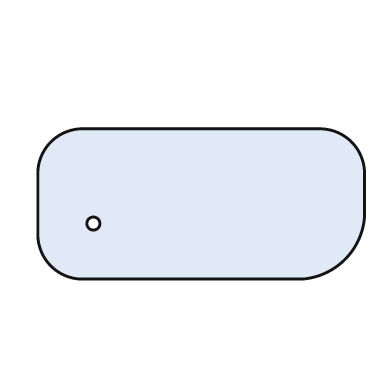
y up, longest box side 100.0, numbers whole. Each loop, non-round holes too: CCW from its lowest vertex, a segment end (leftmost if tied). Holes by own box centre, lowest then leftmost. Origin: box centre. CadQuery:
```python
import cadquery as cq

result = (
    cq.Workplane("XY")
    .moveTo(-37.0, -23.0)
    .lineTo(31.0, -23.0)
    .threePointArc((44.0, -17.0), (50.0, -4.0))
    .lineTo(50.0, 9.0)
    .threePointArc((46.0, 19.0), (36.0, 23.0))
    .lineTo(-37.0, 23.0)
    .threePointArc((-46.0, 19.0), (-50.0, 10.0))
    .lineTo(-50.0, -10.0)
    .threePointArc((-46.0, -19.0), (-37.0, -23.0))
    .close()
    .moveTo(-33.0, -6.0)
    .circle(2.0)
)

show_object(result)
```